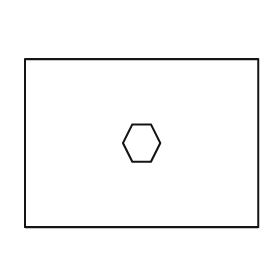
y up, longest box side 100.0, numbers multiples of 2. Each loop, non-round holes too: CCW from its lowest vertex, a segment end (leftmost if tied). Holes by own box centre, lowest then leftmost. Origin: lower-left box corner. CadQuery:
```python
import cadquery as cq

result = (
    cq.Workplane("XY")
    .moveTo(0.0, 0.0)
    .lineTo(100.0, 0.0)
    .lineTo(100.0, 72.0)
    .lineTo(0.0, 72.0)
    .close()
    .moveTo(46.0, 28.0)
    .lineTo(54.0, 28.0)
    .lineTo(58.0, 36.0)
    .lineTo(54.0, 44.0)
    .lineTo(46.0, 44.0)
    .lineTo(42.0, 36.0)
    .close()
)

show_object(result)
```